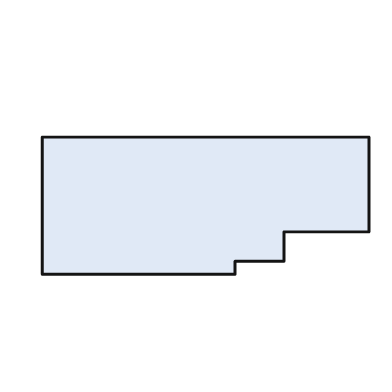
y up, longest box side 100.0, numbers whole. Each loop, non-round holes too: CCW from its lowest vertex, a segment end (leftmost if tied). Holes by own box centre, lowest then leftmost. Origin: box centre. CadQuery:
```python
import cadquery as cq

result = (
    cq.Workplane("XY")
    .moveTo(-50.0, -21.0)
    .lineTo(9.0, -21.0)
    .lineTo(9.0, -17.0)
    .lineTo(24.0, -17.0)
    .lineTo(24.0, -8.0)
    .lineTo(50.0, -8.0)
    .lineTo(50.0, 21.0)
    .lineTo(-50.0, 21.0)
    .close()
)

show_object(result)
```